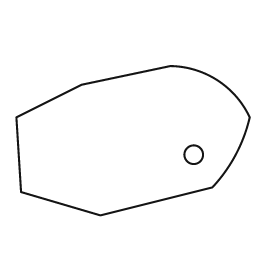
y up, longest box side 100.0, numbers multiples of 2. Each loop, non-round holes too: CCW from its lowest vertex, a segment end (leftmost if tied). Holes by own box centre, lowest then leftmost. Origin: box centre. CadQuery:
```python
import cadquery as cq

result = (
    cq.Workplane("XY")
    .moveTo(-14.0, -32.0)
    .lineTo(34.0, -20.0)
    .threePointArc((44.0, -6.0), (50.0, 10.0))
    .threePointArc((36.0, 26.0), (16.0, 32.0))
    .lineTo(-22.0, 24.0)
    .lineTo(-50.0, 10.0)
    .lineTo(-48.0, -22.0)
    .close()
    .moveTo(26.0, -6.0)
    .circle(4.0)
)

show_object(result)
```